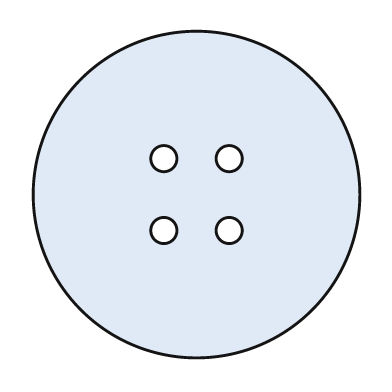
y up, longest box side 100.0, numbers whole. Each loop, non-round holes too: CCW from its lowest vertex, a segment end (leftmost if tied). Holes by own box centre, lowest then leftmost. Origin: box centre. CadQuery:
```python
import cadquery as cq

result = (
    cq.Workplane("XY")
    .moveTo(0.0, 0.0)
    .circle(50.0)
    .moveTo(-10.0, -11.0)
    .circle(4.0)
    .moveTo(10.0, -11.0)
    .circle(4.0)
    .moveTo(-10.0, 11.0)
    .circle(4.0)
    .moveTo(10.0, 11.0)
    .circle(4.0)
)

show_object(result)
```